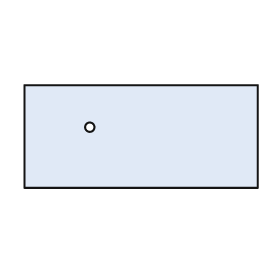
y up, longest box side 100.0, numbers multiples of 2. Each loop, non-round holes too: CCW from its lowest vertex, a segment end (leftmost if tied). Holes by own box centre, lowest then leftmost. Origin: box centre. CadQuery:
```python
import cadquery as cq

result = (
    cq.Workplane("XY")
    .moveTo(-50.0, -22.0)
    .lineTo(50.0, -22.0)
    .lineTo(50.0, 22.0)
    .lineTo(-50.0, 22.0)
    .close()
    .moveTo(-22.0, 4.0)
    .circle(2.0)
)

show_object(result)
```